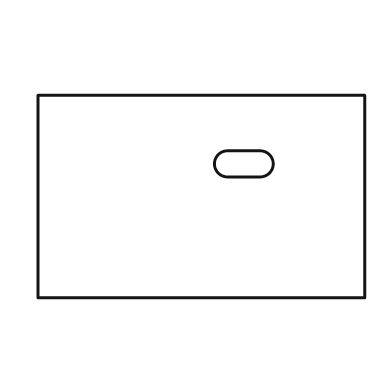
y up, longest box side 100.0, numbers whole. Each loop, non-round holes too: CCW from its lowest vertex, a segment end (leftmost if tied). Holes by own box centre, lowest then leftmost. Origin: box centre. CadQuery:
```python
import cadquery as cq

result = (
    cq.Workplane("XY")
    .moveTo(-50.0, -31.0)
    .lineTo(50.0, -31.0)
    .lineTo(50.0, 31.0)
    .lineTo(-50.0, 31.0)
    .close()
    .moveTo(8.0, 6.0)
    .lineTo(18.0, 6.0)
    .threePointArc((22.0, 10.0), (18.0, 14.0))
    .lineTo(8.0, 14.0)
    .threePointArc((4.0, 10.0), (8.0, 6.0))
    .close()
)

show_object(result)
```